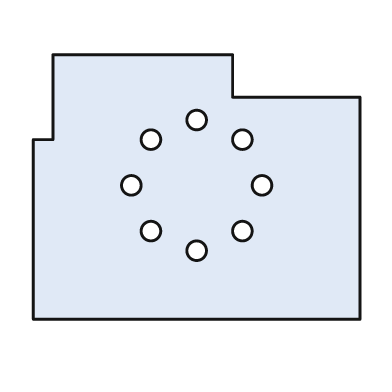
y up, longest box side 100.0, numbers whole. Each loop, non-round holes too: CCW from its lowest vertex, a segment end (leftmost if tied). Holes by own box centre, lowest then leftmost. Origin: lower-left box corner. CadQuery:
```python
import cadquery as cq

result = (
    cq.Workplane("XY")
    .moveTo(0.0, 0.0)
    .lineTo(100.0, 0.0)
    .lineTo(100.0, 68.0)
    .lineTo(61.0, 68.0)
    .lineTo(61.0, 81.0)
    .lineTo(6.0, 81.0)
    .lineTo(6.0, 55.0)
    .lineTo(0.0, 55.0)
    .close()
    .moveTo(50.0, 21.0)
    .circle(3.0)
    .moveTo(36.0, 27.0)
    .circle(3.0)
    .moveTo(64.0, 27.0)
    .circle(3.0)
    .moveTo(30.0, 41.0)
    .circle(3.0)
    .moveTo(70.0, 41.0)
    .circle(3.0)
    .moveTo(36.0, 55.0)
    .circle(3.0)
    .moveTo(64.0, 55.0)
    .circle(3.0)
    .moveTo(50.0, 61.0)
    .circle(3.0)
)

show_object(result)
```